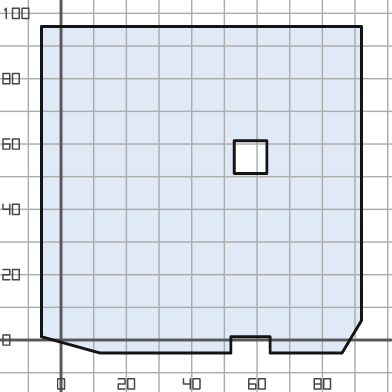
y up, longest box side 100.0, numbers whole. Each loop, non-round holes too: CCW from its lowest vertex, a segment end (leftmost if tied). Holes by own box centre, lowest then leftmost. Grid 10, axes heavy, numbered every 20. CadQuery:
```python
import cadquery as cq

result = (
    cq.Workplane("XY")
    .moveTo(12.0, -4.0)
    .lineTo(52.0, -4.0)
    .lineTo(52.0, 1.0)
    .lineTo(64.0, 1.0)
    .lineTo(64.0, -4.0)
    .lineTo(86.0, -4.0)
    .lineTo(92.0, 6.0)
    .lineTo(92.0, 96.0)
    .lineTo(-6.0, 96.0)
    .lineTo(-6.0, 1.0)
    .close()
    .moveTo(53.0, 51.0)
    .lineTo(63.0, 51.0)
    .lineTo(63.0, 61.0)
    .lineTo(53.0, 61.0)
    .close()
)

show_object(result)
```